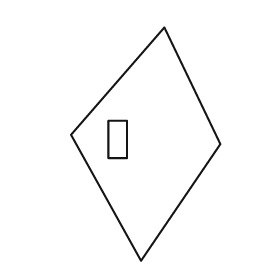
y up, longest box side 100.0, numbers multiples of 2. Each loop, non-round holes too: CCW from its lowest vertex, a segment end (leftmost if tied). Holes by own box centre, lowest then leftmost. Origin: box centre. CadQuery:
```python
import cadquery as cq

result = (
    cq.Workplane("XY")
    .moveTo(-2.0, -50.0)
    .lineTo(32.0, 0.0)
    .lineTo(8.0, 50.0)
    .lineTo(-32.0, 4.0)
    .close()
    .moveTo(-16.0, -6.0)
    .lineTo(-8.0, -6.0)
    .lineTo(-8.0, 10.0)
    .lineTo(-16.0, 10.0)
    .close()
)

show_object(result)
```